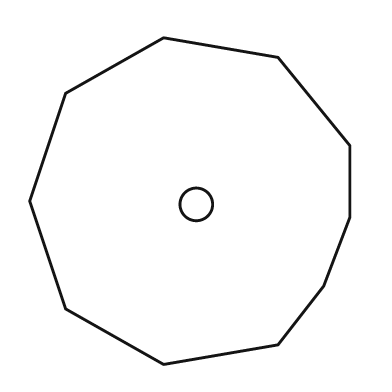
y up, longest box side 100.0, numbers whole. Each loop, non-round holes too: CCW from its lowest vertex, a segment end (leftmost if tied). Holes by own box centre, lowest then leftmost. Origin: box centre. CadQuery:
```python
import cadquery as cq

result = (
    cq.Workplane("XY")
    .moveTo(-8.0, -50.0)
    .lineTo(27.0, -44.0)
    .lineTo(41.0, -26.0)
    .lineTo(49.0, -5.0)
    .lineTo(49.0, 17.0)
    .lineTo(27.0, 44.0)
    .lineTo(-8.0, 50.0)
    .lineTo(-38.0, 33.0)
    .lineTo(-49.0, 0.0)
    .lineTo(-38.0, -33.0)
    .close()
    .moveTo(2.0, -1.0)
    .circle(5.0)
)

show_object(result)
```